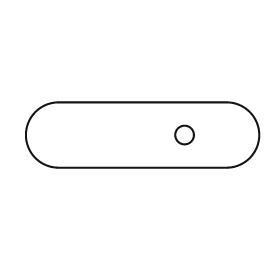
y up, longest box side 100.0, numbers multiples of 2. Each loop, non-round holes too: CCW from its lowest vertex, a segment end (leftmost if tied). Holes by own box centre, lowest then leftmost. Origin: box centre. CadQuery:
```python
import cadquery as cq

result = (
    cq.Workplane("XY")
    .moveTo(-36.0, -14.0)
    .lineTo(36.0, -14.0)
    .threePointArc((50.0, 0.0), (36.0, 14.0))
    .lineTo(-36.0, 14.0)
    .threePointArc((-50.0, 0.0), (-36.0, -14.0))
    .close()
    .moveTo(18.0, 0.0)
    .circle(4.0)
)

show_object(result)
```